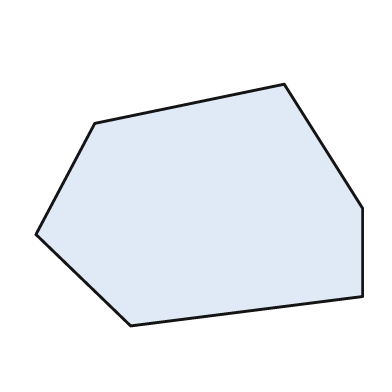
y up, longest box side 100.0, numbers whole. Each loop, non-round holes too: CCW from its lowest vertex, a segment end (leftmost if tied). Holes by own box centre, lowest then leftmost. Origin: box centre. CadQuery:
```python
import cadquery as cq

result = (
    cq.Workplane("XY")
    .moveTo(-21.0, -37.0)
    .lineTo(50.0, -28.0)
    .lineTo(50.0, -1.0)
    .lineTo(26.0, 37.0)
    .lineTo(-32.0, 25.0)
    .lineTo(-50.0, -9.0)
    .close()
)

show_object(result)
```